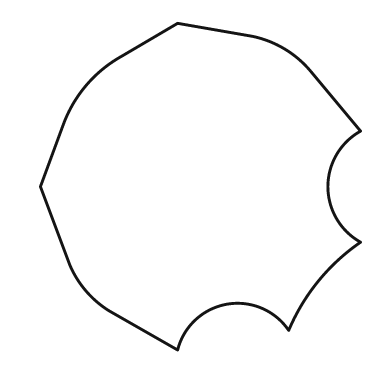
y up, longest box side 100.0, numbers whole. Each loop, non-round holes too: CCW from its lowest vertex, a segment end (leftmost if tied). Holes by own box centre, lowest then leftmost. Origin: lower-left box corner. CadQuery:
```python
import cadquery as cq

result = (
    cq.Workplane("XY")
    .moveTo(42.0, 0.0)
    .threePointArc((57.0, 14.0), (76.0, 6.0))
    .threePointArc((85.0, 21.0), (98.0, 33.0))
    .threePointArc((88.0, 50.0), (98.0, 67.0))
    .lineTo(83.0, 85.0)
    .threePointArc((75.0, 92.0), (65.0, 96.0))
    .lineTo(42.0, 100.0)
    .lineTo(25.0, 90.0)
    .threePointArc((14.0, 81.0), (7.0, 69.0))
    .lineTo(0.0, 50.0)
    .lineTo(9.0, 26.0)
    .threePointArc((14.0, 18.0), (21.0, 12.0))
    .close()
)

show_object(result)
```